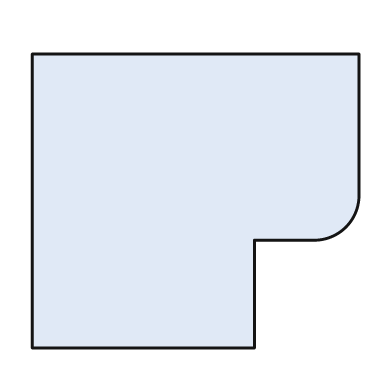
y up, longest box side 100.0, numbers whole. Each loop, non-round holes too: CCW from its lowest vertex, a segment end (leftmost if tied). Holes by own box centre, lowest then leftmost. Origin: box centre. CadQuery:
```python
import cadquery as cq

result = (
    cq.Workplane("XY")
    .moveTo(-50.0, -45.0)
    .lineTo(18.0, -45.0)
    .lineTo(18.0, -12.0)
    .lineTo(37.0, -12.0)
    .threePointArc((46.0, -8.0), (50.0, 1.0))
    .lineTo(50.0, 45.0)
    .lineTo(-50.0, 45.0)
    .close()
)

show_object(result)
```